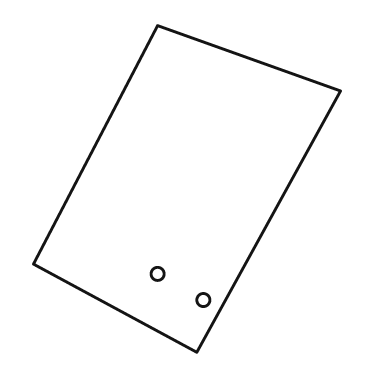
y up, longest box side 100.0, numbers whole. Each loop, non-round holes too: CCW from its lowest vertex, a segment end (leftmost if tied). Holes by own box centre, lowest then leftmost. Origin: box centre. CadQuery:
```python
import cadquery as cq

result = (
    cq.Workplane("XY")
    .moveTo(3.0, -50.0)
    .lineTo(47.0, 30.0)
    .lineTo(-9.0, 50.0)
    .lineTo(-47.0, -23.0)
    .close()
    .moveTo(5.0, -34.0)
    .circle(2.0)
    .moveTo(-9.0, -26.0)
    .circle(2.0)
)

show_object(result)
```